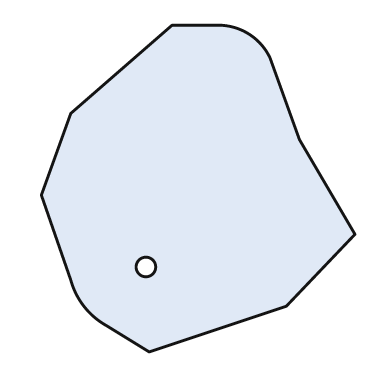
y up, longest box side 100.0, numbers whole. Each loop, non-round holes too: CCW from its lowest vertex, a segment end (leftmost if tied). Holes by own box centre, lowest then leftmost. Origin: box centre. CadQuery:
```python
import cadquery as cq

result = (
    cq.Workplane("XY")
    .moveTo(-15.0, -50.0)
    .lineTo(27.0, -36.0)
    .lineTo(48.0, -14.0)
    .lineTo(31.0, 15.0)
    .lineTo(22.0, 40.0)
    .threePointArc((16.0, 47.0), (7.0, 50.0))
    .lineTo(-8.0, 50.0)
    .lineTo(-39.0, 23.0)
    .lineTo(-48.0, -2.0)
    .lineTo(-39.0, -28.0)
    .threePointArc((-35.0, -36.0), (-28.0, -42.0))
    .close()
    .moveTo(-16.0, -24.0)
    .circle(3.0)
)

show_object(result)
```